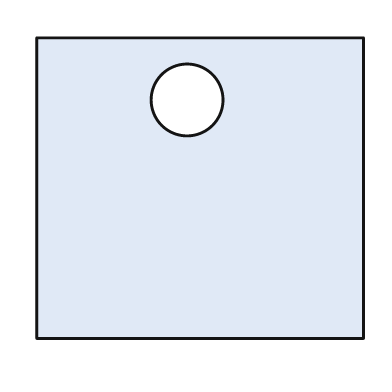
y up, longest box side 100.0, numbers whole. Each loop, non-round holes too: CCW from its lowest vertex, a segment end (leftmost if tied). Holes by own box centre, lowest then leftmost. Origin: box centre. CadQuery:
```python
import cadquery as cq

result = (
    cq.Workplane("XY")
    .moveTo(-50.0, -46.0)
    .lineTo(50.0, -46.0)
    .lineTo(50.0, 46.0)
    .lineTo(-50.0, 46.0)
    .close()
    .moveTo(-4.0, 27.0)
    .circle(11.0)
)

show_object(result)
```